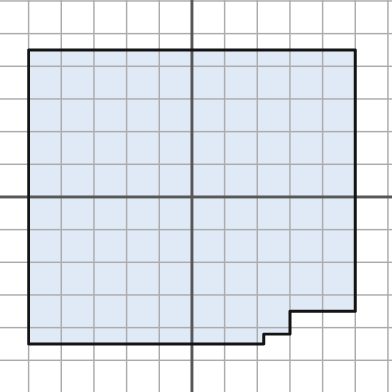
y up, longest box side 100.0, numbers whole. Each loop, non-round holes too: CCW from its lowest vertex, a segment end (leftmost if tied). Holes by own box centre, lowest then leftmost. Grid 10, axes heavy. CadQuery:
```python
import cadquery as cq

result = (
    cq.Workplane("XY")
    .moveTo(-50.0, -45.0)
    .lineTo(22.0, -45.0)
    .lineTo(22.0, -42.0)
    .lineTo(30.0, -42.0)
    .lineTo(30.0, -35.0)
    .lineTo(50.0, -35.0)
    .lineTo(50.0, 45.0)
    .lineTo(-50.0, 45.0)
    .close()
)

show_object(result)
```